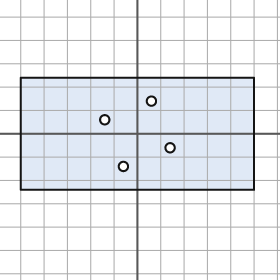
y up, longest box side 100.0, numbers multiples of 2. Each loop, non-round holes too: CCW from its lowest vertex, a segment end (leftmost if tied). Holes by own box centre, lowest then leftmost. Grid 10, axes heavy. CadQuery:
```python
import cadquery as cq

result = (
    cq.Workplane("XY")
    .moveTo(-50.0, -24.0)
    .lineTo(50.0, -24.0)
    .lineTo(50.0, 24.0)
    .lineTo(-50.0, 24.0)
    .close()
    .moveTo(-6.0, -14.0)
    .circle(2.0)
    .moveTo(14.0, -6.0)
    .circle(2.0)
    .moveTo(-14.0, 6.0)
    .circle(2.0)
    .moveTo(6.0, 14.0)
    .circle(2.0)
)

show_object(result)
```